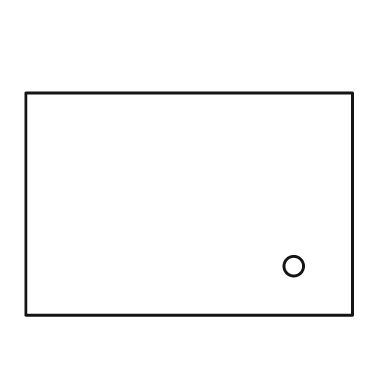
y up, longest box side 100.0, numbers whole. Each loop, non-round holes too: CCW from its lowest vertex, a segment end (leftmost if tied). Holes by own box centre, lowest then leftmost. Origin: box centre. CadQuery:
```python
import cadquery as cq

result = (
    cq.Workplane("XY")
    .moveTo(-50.0, -34.0)
    .lineTo(50.0, -34.0)
    .lineTo(50.0, 34.0)
    .lineTo(-50.0, 34.0)
    .close()
    .moveTo(32.0, -19.0)
    .circle(3.0)
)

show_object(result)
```